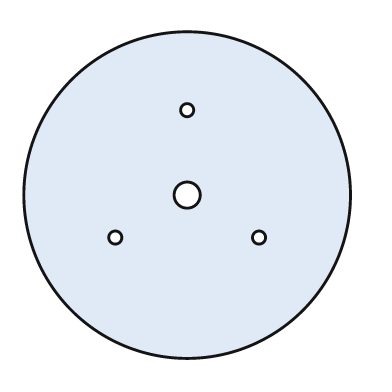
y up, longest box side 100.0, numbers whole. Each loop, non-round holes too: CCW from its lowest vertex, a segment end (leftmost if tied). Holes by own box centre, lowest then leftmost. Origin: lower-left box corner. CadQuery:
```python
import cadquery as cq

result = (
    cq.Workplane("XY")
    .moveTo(50.0, 50.0)
    .circle(50.0)
    .moveTo(28.0, 37.0)
    .circle(2.0)
    .moveTo(72.0, 37.0)
    .circle(2.0)
    .moveTo(50.0, 50.0)
    .circle(4.0)
    .moveTo(50.0, 76.0)
    .circle(2.0)
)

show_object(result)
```